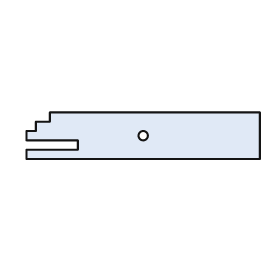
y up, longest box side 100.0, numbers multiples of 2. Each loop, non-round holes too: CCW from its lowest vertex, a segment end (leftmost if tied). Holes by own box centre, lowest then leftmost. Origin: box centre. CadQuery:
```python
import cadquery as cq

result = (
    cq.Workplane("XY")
    .moveTo(-50.0, -10.0)
    .lineTo(50.0, -10.0)
    .lineTo(50.0, 10.0)
    .lineTo(-40.0, 10.0)
    .lineTo(-40.0, 6.0)
    .lineTo(-46.0, 6.0)
    .lineTo(-46.0, 2.0)
    .lineTo(-50.0, 2.0)
    .lineTo(-50.0, -2.0)
    .lineTo(-28.0, -2.0)
    .lineTo(-28.0, -6.0)
    .lineTo(-50.0, -6.0)
    .close()
    .moveTo(0.0, 0.0)
    .circle(2.0)
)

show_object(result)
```